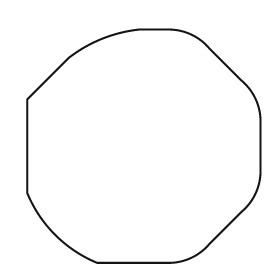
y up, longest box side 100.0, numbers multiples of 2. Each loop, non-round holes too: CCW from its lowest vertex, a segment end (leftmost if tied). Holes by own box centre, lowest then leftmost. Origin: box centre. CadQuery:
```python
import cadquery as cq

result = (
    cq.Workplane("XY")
    .moveTo(-20.0, -50.0)
    .lineTo(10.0, -50.0)
    .threePointArc((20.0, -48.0), (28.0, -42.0))
    .lineTo(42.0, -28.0)
    .threePointArc((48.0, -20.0), (50.0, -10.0))
    .lineTo(50.0, 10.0)
    .threePointArc((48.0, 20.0), (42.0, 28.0))
    .lineTo(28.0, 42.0)
    .threePointArc((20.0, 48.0), (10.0, 50.0))
    .lineTo(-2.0, 50.0)
    .threePointArc((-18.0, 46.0), (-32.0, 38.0))
    .lineTo(-50.0, 20.0)
    .lineTo(-50.0, -20.0)
    .threePointArc((-38.0, -38.0), (-20.0, -50.0))
    .close()
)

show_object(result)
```